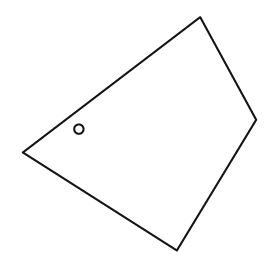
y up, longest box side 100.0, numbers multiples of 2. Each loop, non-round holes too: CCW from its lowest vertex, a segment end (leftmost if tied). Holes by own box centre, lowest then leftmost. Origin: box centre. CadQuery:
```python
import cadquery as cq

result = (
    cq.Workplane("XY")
    .moveTo(16.0, -50.0)
    .lineTo(50.0, 6.0)
    .lineTo(26.0, 50.0)
    .lineTo(-50.0, -8.0)
    .close()
    .moveTo(-26.0, 2.0)
    .circle(2.0)
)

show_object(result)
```